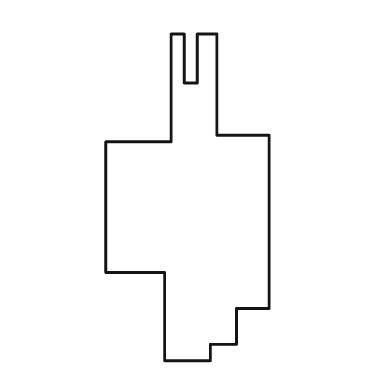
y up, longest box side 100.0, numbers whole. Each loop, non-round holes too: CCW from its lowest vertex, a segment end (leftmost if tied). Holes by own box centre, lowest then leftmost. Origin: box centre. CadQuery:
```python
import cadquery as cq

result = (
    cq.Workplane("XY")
    .moveTo(-7.0, -50.0)
    .lineTo(7.0, -50.0)
    .lineTo(7.0, -45.0)
    .lineTo(15.0, -45.0)
    .lineTo(15.0, -34.0)
    .lineTo(25.0, -34.0)
    .lineTo(25.0, 19.0)
    .lineTo(9.0, 19.0)
    .lineTo(9.0, 50.0)
    .lineTo(3.0, 50.0)
    .lineTo(3.0, 35.0)
    .lineTo(-1.0, 35.0)
    .lineTo(-1.0, 50.0)
    .lineTo(-5.0, 50.0)
    .lineTo(-5.0, 17.0)
    .lineTo(-25.0, 17.0)
    .lineTo(-25.0, -23.0)
    .lineTo(-7.0, -23.0)
    .close()
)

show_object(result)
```